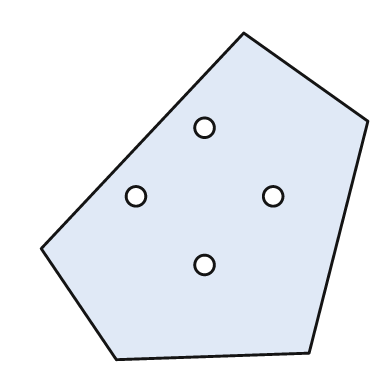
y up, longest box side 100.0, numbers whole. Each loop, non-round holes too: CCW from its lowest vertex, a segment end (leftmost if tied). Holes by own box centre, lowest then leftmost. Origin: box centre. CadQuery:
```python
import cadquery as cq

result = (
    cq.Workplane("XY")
    .moveTo(-27.0, -50.0)
    .lineTo(32.0, -48.0)
    .lineTo(50.0, 23.0)
    .lineTo(12.0, 50.0)
    .lineTo(-50.0, -16.0)
    .close()
    .moveTo(0.0, -21.0)
    .circle(3.0)
    .moveTo(-21.0, 0.0)
    .circle(3.0)
    .moveTo(21.0, 0.0)
    .circle(3.0)
    .moveTo(0.0, 21.0)
    .circle(3.0)
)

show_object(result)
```